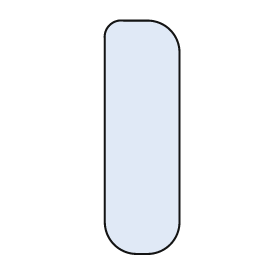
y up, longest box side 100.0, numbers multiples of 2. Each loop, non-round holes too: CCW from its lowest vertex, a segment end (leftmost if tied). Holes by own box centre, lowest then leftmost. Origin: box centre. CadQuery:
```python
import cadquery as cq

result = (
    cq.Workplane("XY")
    .moveTo(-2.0, -50.0)
    .lineTo(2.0, -50.0)
    .threePointArc((12.0, -46.0), (16.0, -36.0))
    .lineTo(16.0, 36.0)
    .threePointArc((12.0, 46.0), (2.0, 50.0))
    .lineTo(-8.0, 50.0)
    .threePointArc((-14.0, 48.0), (-16.0, 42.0))
    .lineTo(-16.0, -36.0)
    .threePointArc((-12.0, -46.0), (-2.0, -50.0))
    .close()
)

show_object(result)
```